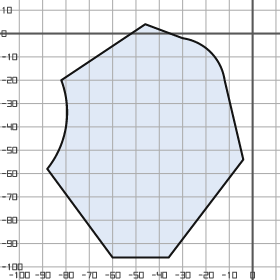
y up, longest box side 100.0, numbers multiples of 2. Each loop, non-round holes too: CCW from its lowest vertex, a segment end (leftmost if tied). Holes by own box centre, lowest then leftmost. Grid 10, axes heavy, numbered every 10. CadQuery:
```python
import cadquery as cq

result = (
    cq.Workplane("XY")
    .moveTo(-60.0, -96.0)
    .lineTo(-36.0, -96.0)
    .lineTo(-4.0, -54.0)
    .lineTo(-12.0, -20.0)
    .threePointArc((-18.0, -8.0), (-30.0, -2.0))
    .lineTo(-46.0, 4.0)
    .lineTo(-82.0, -20.0)
    .threePointArc((-80.0, -40.0), (-88.0, -58.0))
    .close()
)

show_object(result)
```